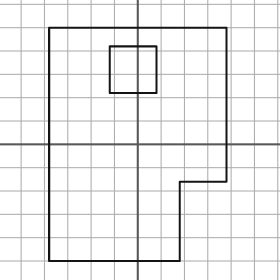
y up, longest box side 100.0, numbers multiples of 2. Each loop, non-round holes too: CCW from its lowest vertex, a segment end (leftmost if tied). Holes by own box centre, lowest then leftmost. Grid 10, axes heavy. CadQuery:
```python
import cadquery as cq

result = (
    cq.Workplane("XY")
    .moveTo(-38.0, -50.0)
    .lineTo(18.0, -50.0)
    .lineTo(18.0, -16.0)
    .lineTo(38.0, -16.0)
    .lineTo(38.0, 50.0)
    .lineTo(-38.0, 50.0)
    .close()
    .moveTo(-12.0, 22.0)
    .lineTo(8.0, 22.0)
    .lineTo(8.0, 42.0)
    .lineTo(-12.0, 42.0)
    .close()
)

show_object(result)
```